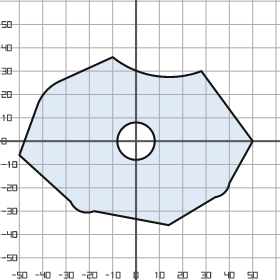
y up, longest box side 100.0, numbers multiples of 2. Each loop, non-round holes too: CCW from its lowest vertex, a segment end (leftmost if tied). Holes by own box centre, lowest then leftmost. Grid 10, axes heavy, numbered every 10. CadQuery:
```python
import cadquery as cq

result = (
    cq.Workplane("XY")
    .moveTo(14.0, -36.0)
    .lineTo(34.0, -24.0)
    .threePointArc((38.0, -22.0), (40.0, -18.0))
    .lineTo(50.0, 0.0)
    .lineTo(28.0, 30.0)
    .threePointArc((8.0, 28.0), (-10.0, 36.0))
    .lineTo(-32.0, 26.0)
    .threePointArc((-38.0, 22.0), (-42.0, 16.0))
    .lineTo(-50.0, -6.0)
    .lineTo(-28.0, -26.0)
    .threePointArc((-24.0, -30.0), (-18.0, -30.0))
    .close()
    .moveTo(0.0, 0.0)
    .circle(8.0)
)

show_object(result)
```